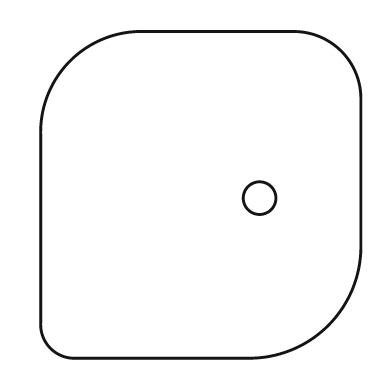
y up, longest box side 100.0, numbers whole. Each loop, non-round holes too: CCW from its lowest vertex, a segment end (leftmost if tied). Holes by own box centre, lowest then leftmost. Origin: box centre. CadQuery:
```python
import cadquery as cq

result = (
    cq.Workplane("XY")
    .moveTo(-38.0, -50.0)
    .lineTo(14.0, -50.0)
    .threePointArc((39.0, -40.0), (49.0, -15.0))
    .lineTo(49.0, 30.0)
    .threePointArc((43.0, 44.0), (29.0, 50.0))
    .lineTo(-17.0, 50.0)
    .threePointArc((-40.0, 41.0), (-49.0, 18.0))
    .lineTo(-49.0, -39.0)
    .threePointArc((-46.0, -47.0), (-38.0, -50.0))
    .close()
    .moveTo(18.0, -1.0)
    .circle(5.0)
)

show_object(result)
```